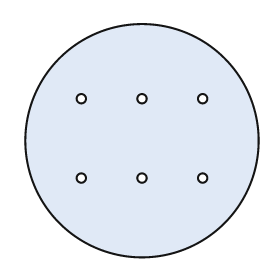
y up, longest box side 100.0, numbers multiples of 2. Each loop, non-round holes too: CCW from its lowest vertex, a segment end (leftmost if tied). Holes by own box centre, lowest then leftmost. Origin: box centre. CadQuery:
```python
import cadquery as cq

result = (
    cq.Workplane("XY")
    .moveTo(0.0, 0.0)
    .circle(50.0)
    .moveTo(-26.0, -16.0)
    .circle(2.0)
    .moveTo(0.0, -16.0)
    .circle(2.0)
    .moveTo(26.0, -16.0)
    .circle(2.0)
    .moveTo(-26.0, 18.0)
    .circle(2.0)
    .moveTo(0.0, 18.0)
    .circle(2.0)
    .moveTo(26.0, 18.0)
    .circle(2.0)
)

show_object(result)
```